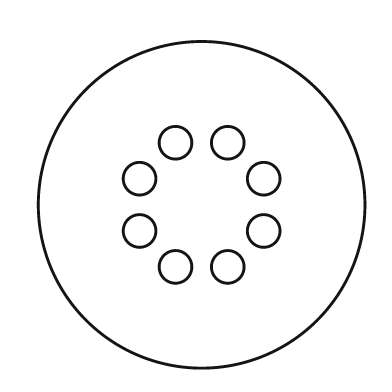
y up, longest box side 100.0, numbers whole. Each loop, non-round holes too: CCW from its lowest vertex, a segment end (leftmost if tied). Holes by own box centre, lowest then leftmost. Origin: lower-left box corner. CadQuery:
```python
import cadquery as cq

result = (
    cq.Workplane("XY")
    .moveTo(50.0, 50.0)
    .circle(50.0)
    .moveTo(42.0, 31.0)
    .circle(5.0)
    .moveTo(58.0, 31.0)
    .circle(5.0)
    .moveTo(31.0, 42.0)
    .circle(5.0)
    .moveTo(69.0, 42.0)
    .circle(5.0)
    .moveTo(31.0, 58.0)
    .circle(5.0)
    .moveTo(69.0, 58.0)
    .circle(5.0)
    .moveTo(42.0, 69.0)
    .circle(5.0)
    .moveTo(58.0, 69.0)
    .circle(5.0)
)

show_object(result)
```